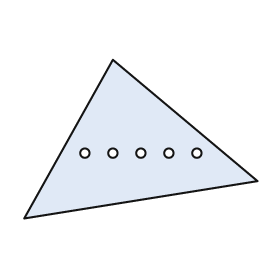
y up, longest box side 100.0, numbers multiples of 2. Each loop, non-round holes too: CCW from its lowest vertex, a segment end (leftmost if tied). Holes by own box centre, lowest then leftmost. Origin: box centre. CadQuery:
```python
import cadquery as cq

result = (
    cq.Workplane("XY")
    .moveTo(-50.0, -34.0)
    .lineTo(50.0, -18.0)
    .lineTo(-12.0, 34.0)
    .close()
    .moveTo(-24.0, -6.0)
    .circle(2.0)
    .moveTo(-12.0, -6.0)
    .circle(2.0)
    .moveTo(0.0, -6.0)
    .circle(2.0)
    .moveTo(12.0, -6.0)
    .circle(2.0)
    .moveTo(24.0, -6.0)
    .circle(2.0)
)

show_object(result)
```